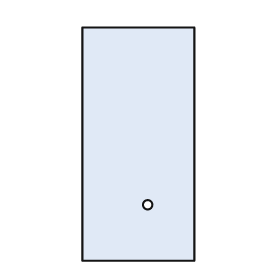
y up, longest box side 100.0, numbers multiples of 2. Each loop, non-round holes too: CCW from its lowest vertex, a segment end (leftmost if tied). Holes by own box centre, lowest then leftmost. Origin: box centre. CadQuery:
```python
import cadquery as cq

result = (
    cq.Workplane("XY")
    .moveTo(-24.0, -50.0)
    .lineTo(24.0, -50.0)
    .lineTo(24.0, 50.0)
    .lineTo(-24.0, 50.0)
    .close()
    .moveTo(4.0, -26.0)
    .circle(2.0)
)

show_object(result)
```